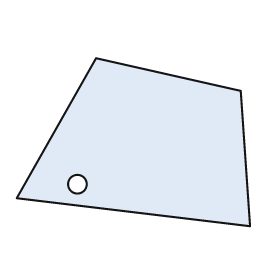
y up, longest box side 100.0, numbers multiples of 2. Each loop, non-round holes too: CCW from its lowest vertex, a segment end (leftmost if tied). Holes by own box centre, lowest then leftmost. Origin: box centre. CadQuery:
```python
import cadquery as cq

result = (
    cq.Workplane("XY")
    .moveTo(50.0, -36.0)
    .lineTo(46.0, 22.0)
    .lineTo(-16.0, 36.0)
    .lineTo(-50.0, -24.0)
    .close()
    .moveTo(-24.0, -18.0)
    .circle(4.0)
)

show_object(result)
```